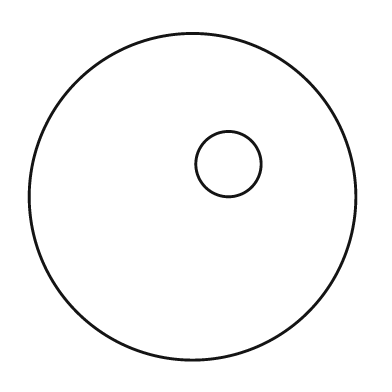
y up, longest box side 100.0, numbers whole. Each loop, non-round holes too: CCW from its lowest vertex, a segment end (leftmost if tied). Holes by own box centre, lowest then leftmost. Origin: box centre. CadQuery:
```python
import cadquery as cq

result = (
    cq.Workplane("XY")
    .moveTo(0.0, 0.0)
    .circle(50.0)
    .moveTo(11.0, 10.0)
    .circle(10.0)
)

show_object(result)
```